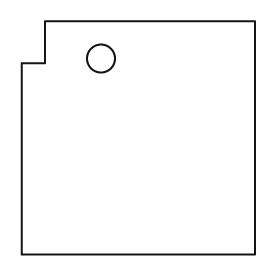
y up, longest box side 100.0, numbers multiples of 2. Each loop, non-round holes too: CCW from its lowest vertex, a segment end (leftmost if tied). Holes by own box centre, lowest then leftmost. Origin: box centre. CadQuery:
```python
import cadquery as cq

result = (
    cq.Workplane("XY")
    .moveTo(-50.0, -50.0)
    .lineTo(50.0, -50.0)
    .lineTo(50.0, 50.0)
    .lineTo(-40.0, 50.0)
    .lineTo(-40.0, 32.0)
    .lineTo(-50.0, 32.0)
    .close()
    .moveTo(-16.0, 34.0)
    .circle(6.0)
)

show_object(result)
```